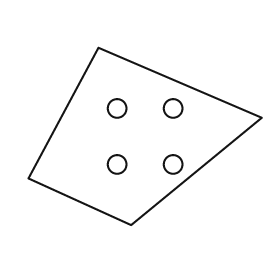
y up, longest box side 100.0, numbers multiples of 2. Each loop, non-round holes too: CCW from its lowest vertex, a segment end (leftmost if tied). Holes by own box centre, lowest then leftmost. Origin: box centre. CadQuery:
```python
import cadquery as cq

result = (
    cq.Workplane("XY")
    .moveTo(-6.0, -38.0)
    .lineTo(50.0, 8.0)
    .lineTo(-20.0, 38.0)
    .lineTo(-50.0, -18.0)
    .close()
    .moveTo(-12.0, -12.0)
    .circle(4.0)
    .moveTo(12.0, -12.0)
    .circle(4.0)
    .moveTo(-12.0, 12.0)
    .circle(4.0)
    .moveTo(12.0, 12.0)
    .circle(4.0)
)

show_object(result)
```